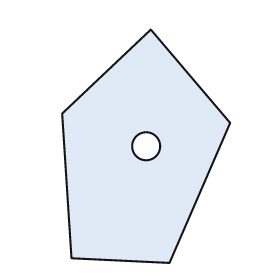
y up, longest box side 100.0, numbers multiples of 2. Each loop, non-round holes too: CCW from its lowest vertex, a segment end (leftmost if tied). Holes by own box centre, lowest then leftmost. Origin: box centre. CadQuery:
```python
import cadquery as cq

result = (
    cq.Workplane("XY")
    .moveTo(10.0, -50.0)
    .lineTo(36.0, 10.0)
    .lineTo(2.0, 50.0)
    .lineTo(-36.0, 14.0)
    .lineTo(-32.0, -48.0)
    .close()
    .moveTo(0.0, 0.0)
    .circle(6.0)
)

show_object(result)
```